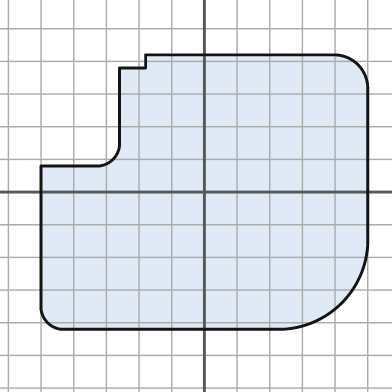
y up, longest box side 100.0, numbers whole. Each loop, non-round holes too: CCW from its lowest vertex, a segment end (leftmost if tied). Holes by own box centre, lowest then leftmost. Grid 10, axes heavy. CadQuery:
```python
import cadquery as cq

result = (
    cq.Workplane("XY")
    .moveTo(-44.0, -42.0)
    .lineTo(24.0, -42.0)
    .threePointArc((42.0, -34.0), (50.0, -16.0))
    .lineTo(50.0, 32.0)
    .threePointArc((47.0, 39.0), (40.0, 42.0))
    .lineTo(-18.0, 42.0)
    .lineTo(-18.0, 38.0)
    .lineTo(-26.0, 38.0)
    .lineTo(-26.0, 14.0)
    .threePointArc((-28.0, 10.0), (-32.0, 8.0))
    .lineTo(-50.0, 8.0)
    .lineTo(-50.0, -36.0)
    .threePointArc((-48.0, -40.0), (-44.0, -42.0))
    .close()
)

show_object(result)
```